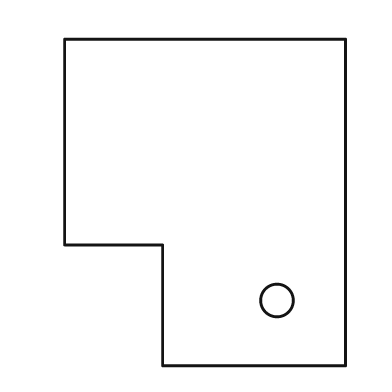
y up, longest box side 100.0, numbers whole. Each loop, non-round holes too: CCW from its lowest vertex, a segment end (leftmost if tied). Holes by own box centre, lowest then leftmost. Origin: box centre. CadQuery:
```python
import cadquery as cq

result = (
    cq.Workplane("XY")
    .moveTo(-13.0, -50.0)
    .lineTo(43.0, -50.0)
    .lineTo(43.0, 50.0)
    .lineTo(-43.0, 50.0)
    .lineTo(-43.0, -13.0)
    .lineTo(-13.0, -13.0)
    .close()
    .moveTo(22.0, -30.0)
    .circle(5.0)
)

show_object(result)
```